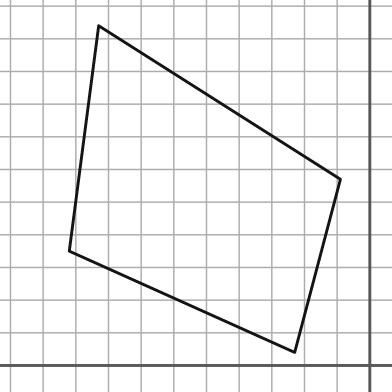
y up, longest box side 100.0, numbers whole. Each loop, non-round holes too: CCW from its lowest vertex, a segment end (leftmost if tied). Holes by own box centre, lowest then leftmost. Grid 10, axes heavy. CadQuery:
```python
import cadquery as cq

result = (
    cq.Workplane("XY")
    .moveTo(-23.0, 4.0)
    .lineTo(-9.0, 57.0)
    .lineTo(-83.0, 104.0)
    .lineTo(-92.0, 35.0)
    .close()
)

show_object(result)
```